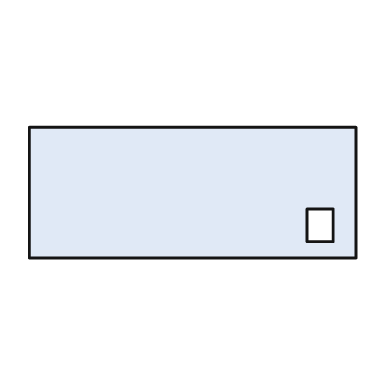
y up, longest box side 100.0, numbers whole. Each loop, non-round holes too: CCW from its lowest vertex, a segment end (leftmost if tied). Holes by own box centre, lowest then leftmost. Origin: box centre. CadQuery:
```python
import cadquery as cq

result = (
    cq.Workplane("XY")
    .moveTo(-50.0, -20.0)
    .lineTo(50.0, -20.0)
    .lineTo(50.0, 20.0)
    .lineTo(-50.0, 20.0)
    .close()
    .moveTo(35.0, -15.0)
    .lineTo(43.0, -15.0)
    .lineTo(43.0, -5.0)
    .lineTo(35.0, -5.0)
    .close()
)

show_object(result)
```